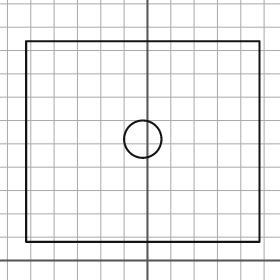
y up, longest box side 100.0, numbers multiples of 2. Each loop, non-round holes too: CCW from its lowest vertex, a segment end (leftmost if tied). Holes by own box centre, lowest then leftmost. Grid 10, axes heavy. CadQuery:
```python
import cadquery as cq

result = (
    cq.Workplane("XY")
    .moveTo(-52.0, 8.0)
    .lineTo(48.0, 8.0)
    .lineTo(48.0, 94.0)
    .lineTo(-52.0, 94.0)
    .close()
    .moveTo(-2.0, 52.0)
    .circle(8.0)
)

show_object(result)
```